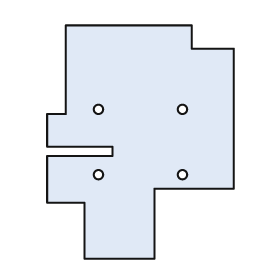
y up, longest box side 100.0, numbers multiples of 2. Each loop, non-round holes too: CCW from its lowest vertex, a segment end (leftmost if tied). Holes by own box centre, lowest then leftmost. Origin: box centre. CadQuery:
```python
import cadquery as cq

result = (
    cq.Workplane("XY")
    .moveTo(-24.0, -50.0)
    .lineTo(6.0, -50.0)
    .lineTo(6.0, -20.0)
    .lineTo(40.0, -20.0)
    .lineTo(40.0, 40.0)
    .lineTo(22.0, 40.0)
    .lineTo(22.0, 50.0)
    .lineTo(-32.0, 50.0)
    .lineTo(-32.0, 12.0)
    .lineTo(-40.0, 12.0)
    .lineTo(-40.0, -2.0)
    .lineTo(-12.0, -2.0)
    .lineTo(-12.0, -6.0)
    .lineTo(-40.0, -6.0)
    .lineTo(-40.0, -26.0)
    .lineTo(-24.0, -26.0)
    .close()
    .moveTo(-18.0, -14.0)
    .circle(2.0)
    .moveTo(18.0, -14.0)
    .circle(2.0)
    .moveTo(-18.0, 14.0)
    .circle(2.0)
    .moveTo(18.0, 14.0)
    .circle(2.0)
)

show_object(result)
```